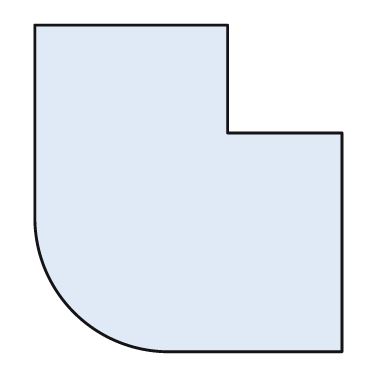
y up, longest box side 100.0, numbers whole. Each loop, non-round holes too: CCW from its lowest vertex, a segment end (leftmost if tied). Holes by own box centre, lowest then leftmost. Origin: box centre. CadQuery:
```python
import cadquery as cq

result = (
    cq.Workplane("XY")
    .moveTo(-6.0, -50.0)
    .lineTo(47.0, -50.0)
    .lineTo(47.0, 17.0)
    .lineTo(12.0, 17.0)
    .lineTo(12.0, 50.0)
    .lineTo(-47.0, 50.0)
    .lineTo(-47.0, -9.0)
    .threePointArc((-35.0, -38.0), (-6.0, -50.0))
    .close()
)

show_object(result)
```